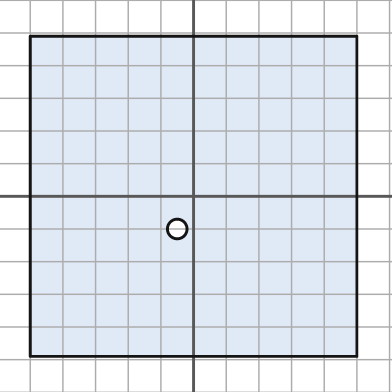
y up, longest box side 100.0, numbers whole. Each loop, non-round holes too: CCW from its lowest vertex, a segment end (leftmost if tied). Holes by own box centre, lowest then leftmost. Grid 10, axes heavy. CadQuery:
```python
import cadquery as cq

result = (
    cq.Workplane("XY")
    .moveTo(-50.0, -49.0)
    .lineTo(50.0, -49.0)
    .lineTo(50.0, 49.0)
    .lineTo(-50.0, 49.0)
    .close()
    .moveTo(-5.0, -10.0)
    .circle(3.0)
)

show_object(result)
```